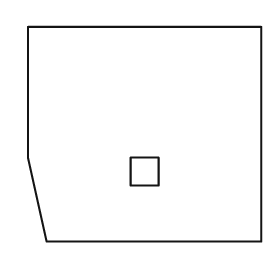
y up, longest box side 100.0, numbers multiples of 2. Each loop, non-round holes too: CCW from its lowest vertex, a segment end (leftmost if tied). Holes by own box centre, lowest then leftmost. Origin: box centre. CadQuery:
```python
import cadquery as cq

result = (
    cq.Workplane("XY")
    .moveTo(-42.0, -46.0)
    .lineTo(50.0, -46.0)
    .lineTo(50.0, 46.0)
    .lineTo(-50.0, 46.0)
    .lineTo(-50.0, -10.0)
    .close()
    .moveTo(-6.0, -22.0)
    .lineTo(6.0, -22.0)
    .lineTo(6.0, -10.0)
    .lineTo(-6.0, -10.0)
    .close()
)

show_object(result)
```